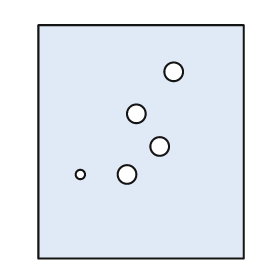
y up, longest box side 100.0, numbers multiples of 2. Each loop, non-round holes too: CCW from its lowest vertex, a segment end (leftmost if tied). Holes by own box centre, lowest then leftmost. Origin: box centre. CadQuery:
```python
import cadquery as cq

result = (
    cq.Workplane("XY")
    .moveTo(-44.0, -50.0)
    .lineTo(44.0, -50.0)
    .lineTo(44.0, 50.0)
    .lineTo(-44.0, 50.0)
    .close()
    .moveTo(-26.0, -14.0)
    .circle(2.0)
    .moveTo(-6.0, -14.0)
    .circle(4.0)
    .moveTo(8.0, -2.0)
    .circle(4.0)
    .moveTo(-2.0, 12.0)
    .circle(4.0)
    .moveTo(14.0, 30.0)
    .circle(4.0)
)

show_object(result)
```